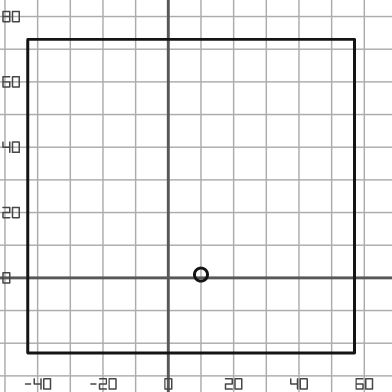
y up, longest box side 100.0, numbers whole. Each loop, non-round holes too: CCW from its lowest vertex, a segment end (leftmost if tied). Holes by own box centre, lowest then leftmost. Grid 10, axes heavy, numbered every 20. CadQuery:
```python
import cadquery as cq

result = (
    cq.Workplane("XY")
    .moveTo(-43.0, -23.0)
    .lineTo(57.0, -23.0)
    .lineTo(57.0, 73.0)
    .lineTo(-43.0, 73.0)
    .close()
    .moveTo(10.0, 1.0)
    .circle(2.0)
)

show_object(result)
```